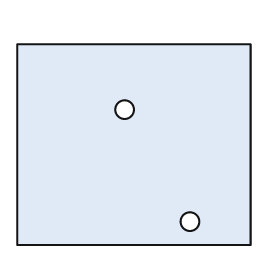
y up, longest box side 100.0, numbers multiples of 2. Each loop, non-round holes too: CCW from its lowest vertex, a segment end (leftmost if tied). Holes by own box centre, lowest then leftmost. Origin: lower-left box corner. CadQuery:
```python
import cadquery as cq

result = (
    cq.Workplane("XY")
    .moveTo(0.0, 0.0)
    .lineTo(100.0, 0.0)
    .lineTo(100.0, 86.0)
    .lineTo(0.0, 86.0)
    .close()
    .moveTo(74.0, 10.0)
    .circle(4.0)
    .moveTo(46.0, 58.0)
    .circle(4.0)
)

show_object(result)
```